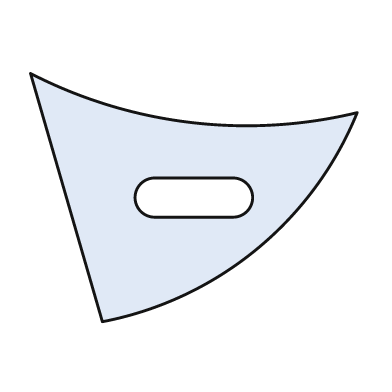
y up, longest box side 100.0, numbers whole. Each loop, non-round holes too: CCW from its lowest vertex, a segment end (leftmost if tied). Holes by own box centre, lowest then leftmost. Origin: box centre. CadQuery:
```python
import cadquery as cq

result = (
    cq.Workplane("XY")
    .moveTo(-28.0, -38.0)
    .threePointArc((19.0, -16.0), (50.0, 26.0))
    .threePointArc((-1.0, 23.0), (-50.0, 38.0))
    .close()
    .moveTo(-12.0, -6.0)
    .lineTo(12.0, -6.0)
    .threePointArc((18.0, 0.0), (12.0, 6.0))
    .lineTo(-12.0, 6.0)
    .threePointArc((-18.0, 0.0), (-12.0, -6.0))
    .close()
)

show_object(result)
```